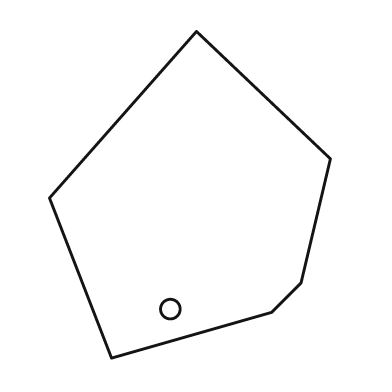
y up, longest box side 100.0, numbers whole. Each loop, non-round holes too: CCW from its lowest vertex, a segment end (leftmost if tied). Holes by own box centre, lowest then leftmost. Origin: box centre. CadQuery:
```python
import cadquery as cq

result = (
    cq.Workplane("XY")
    .moveTo(-24.0, -50.0)
    .lineTo(25.0, -36.0)
    .lineTo(34.0, -27.0)
    .lineTo(43.0, 11.0)
    .lineTo(2.0, 50.0)
    .lineTo(-43.0, -1.0)
    .close()
    .moveTo(-6.0, -35.0)
    .circle(3.0)
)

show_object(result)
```